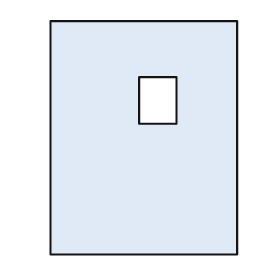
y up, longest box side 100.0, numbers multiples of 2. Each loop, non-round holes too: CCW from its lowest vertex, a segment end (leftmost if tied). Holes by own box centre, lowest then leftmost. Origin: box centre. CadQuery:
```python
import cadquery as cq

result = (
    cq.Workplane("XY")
    .moveTo(-40.0, -50.0)
    .lineTo(40.0, -50.0)
    .lineTo(40.0, 50.0)
    .lineTo(-40.0, 50.0)
    .close()
    .moveTo(-2.0, 6.0)
    .lineTo(14.0, 6.0)
    .lineTo(14.0, 26.0)
    .lineTo(-2.0, 26.0)
    .close()
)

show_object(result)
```